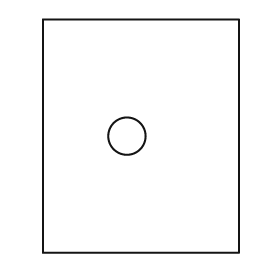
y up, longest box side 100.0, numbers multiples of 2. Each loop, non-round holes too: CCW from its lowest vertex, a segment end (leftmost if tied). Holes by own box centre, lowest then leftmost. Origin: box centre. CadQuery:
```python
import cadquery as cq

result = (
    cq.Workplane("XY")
    .moveTo(-42.0, -50.0)
    .lineTo(42.0, -50.0)
    .lineTo(42.0, 50.0)
    .lineTo(-42.0, 50.0)
    .close()
    .moveTo(-6.0, 0.0)
    .circle(8.0)
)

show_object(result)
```